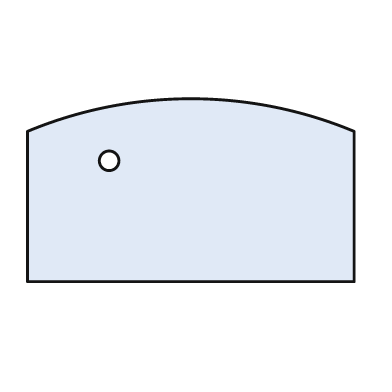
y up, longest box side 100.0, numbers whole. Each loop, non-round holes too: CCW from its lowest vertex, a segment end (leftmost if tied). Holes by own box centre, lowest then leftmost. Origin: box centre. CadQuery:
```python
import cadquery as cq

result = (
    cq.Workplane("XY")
    .moveTo(-50.0, -28.0)
    .lineTo(50.0, -28.0)
    .lineTo(50.0, 18.0)
    .threePointArc((0.0, 28.0), (-50.0, 18.0))
    .close()
    .moveTo(-25.0, 9.0)
    .circle(3.0)
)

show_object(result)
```